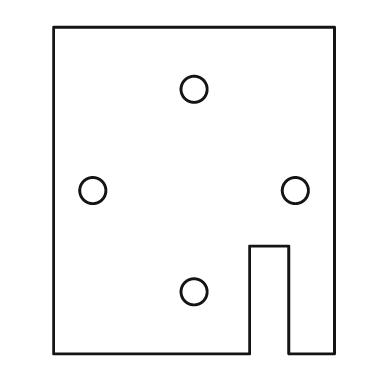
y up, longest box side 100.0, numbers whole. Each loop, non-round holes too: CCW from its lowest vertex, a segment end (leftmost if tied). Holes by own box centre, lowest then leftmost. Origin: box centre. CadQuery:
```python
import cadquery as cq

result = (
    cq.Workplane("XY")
    .moveTo(-43.0, -50.0)
    .lineTo(17.0, -50.0)
    .lineTo(17.0, -17.0)
    .lineTo(29.0, -17.0)
    .lineTo(29.0, -50.0)
    .lineTo(43.0, -50.0)
    .lineTo(43.0, 50.0)
    .lineTo(-43.0, 50.0)
    .close()
    .moveTo(0.0, -31.0)
    .circle(4.0)
    .moveTo(-31.0, 0.0)
    .circle(4.0)
    .moveTo(31.0, 0.0)
    .circle(4.0)
    .moveTo(0.0, 31.0)
    .circle(4.0)
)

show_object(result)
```